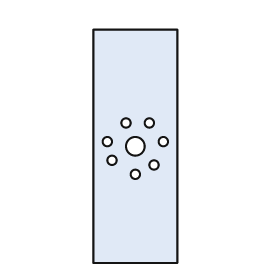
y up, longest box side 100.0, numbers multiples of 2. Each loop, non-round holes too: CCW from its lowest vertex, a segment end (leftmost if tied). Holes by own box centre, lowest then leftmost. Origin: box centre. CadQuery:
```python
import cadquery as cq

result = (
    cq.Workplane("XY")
    .moveTo(-18.0, -50.0)
    .lineTo(18.0, -50.0)
    .lineTo(18.0, 50.0)
    .lineTo(-18.0, 50.0)
    .close()
    .moveTo(0.0, -12.0)
    .circle(2.0)
    .moveTo(8.0, -8.0)
    .circle(2.0)
    .moveTo(-10.0, -6.0)
    .circle(2.0)
    .moveTo(0.0, 0.0)
    .circle(4.0)
    .moveTo(-12.0, 2.0)
    .circle(2.0)
    .moveTo(12.0, 2.0)
    .circle(2.0)
    .moveTo(-4.0, 10.0)
    .circle(2.0)
    .moveTo(6.0, 10.0)
    .circle(2.0)
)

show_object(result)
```